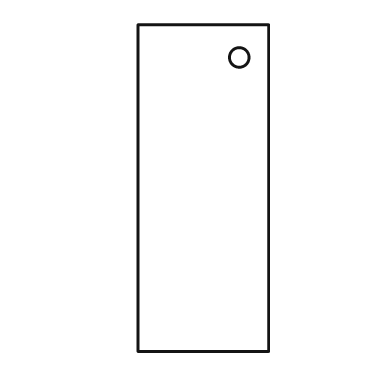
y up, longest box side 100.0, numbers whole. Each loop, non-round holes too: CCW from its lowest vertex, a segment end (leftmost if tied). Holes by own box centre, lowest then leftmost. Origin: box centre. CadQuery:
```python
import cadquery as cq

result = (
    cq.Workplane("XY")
    .moveTo(-20.0, -50.0)
    .lineTo(20.0, -50.0)
    .lineTo(20.0, 50.0)
    .lineTo(-20.0, 50.0)
    .close()
    .moveTo(11.0, 40.0)
    .circle(3.0)
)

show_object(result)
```